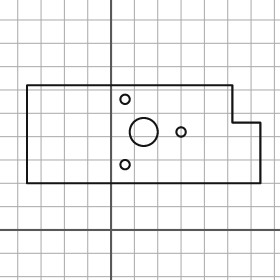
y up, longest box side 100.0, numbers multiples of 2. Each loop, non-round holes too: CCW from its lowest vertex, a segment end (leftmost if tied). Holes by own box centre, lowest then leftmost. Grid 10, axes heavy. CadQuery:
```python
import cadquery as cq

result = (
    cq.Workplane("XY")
    .moveTo(-36.0, 20.0)
    .lineTo(64.0, 20.0)
    .lineTo(64.0, 46.0)
    .lineTo(52.0, 46.0)
    .lineTo(52.0, 62.0)
    .lineTo(-36.0, 62.0)
    .close()
    .moveTo(6.0, 28.0)
    .circle(2.0)
    .moveTo(14.0, 42.0)
    .circle(6.0)
    .moveTo(30.0, 42.0)
    .circle(2.0)
    .moveTo(6.0, 56.0)
    .circle(2.0)
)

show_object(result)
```